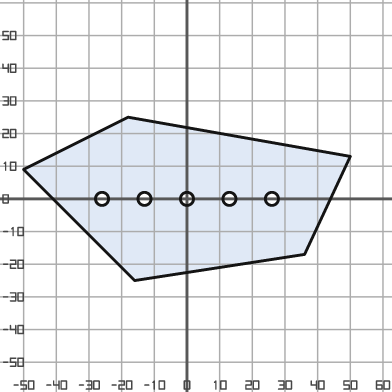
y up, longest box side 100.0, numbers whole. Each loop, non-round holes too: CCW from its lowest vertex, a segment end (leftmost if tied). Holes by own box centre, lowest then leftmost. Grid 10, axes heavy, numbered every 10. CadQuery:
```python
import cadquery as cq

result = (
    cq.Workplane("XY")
    .moveTo(-16.0, -25.0)
    .lineTo(36.0, -17.0)
    .lineTo(50.0, 13.0)
    .lineTo(-18.0, 25.0)
    .lineTo(-50.0, 9.0)
    .close()
    .moveTo(-26.0, 0.0)
    .circle(2.0)
    .moveTo(-13.0, 0.0)
    .circle(2.0)
    .moveTo(0.0, 0.0)
    .circle(2.0)
    .moveTo(13.0, 0.0)
    .circle(2.0)
    .moveTo(26.0, 0.0)
    .circle(2.0)
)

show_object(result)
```